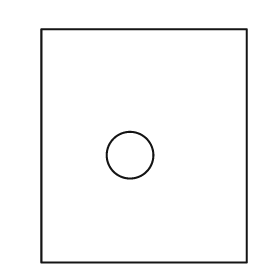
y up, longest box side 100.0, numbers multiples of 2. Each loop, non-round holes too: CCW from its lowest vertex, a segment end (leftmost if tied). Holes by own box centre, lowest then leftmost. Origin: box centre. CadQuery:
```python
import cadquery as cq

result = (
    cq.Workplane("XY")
    .moveTo(-44.0, -50.0)
    .lineTo(44.0, -50.0)
    .lineTo(44.0, 50.0)
    .lineTo(-44.0, 50.0)
    .close()
    .moveTo(-6.0, -4.0)
    .circle(10.0)
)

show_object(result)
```